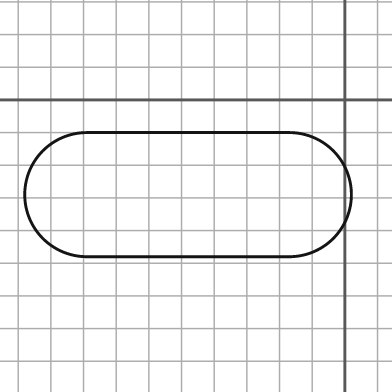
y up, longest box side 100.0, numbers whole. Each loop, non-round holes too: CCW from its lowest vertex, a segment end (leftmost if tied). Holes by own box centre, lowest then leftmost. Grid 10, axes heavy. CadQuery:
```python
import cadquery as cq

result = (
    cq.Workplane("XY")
    .moveTo(-79.0, -48.0)
    .lineTo(-17.0, -48.0)
    .threePointArc((2.0, -29.0), (-17.0, -10.0))
    .lineTo(-79.0, -10.0)
    .threePointArc((-98.0, -29.0), (-79.0, -48.0))
    .close()
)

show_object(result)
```